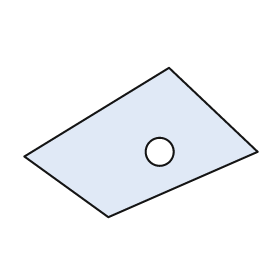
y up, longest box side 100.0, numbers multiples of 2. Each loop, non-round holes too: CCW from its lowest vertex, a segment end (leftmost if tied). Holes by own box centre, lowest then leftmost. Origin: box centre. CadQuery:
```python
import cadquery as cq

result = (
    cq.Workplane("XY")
    .moveTo(-14.0, -32.0)
    .lineTo(50.0, -4.0)
    .lineTo(12.0, 32.0)
    .lineTo(-50.0, -6.0)
    .close()
    .moveTo(8.0, -4.0)
    .circle(6.0)
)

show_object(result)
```